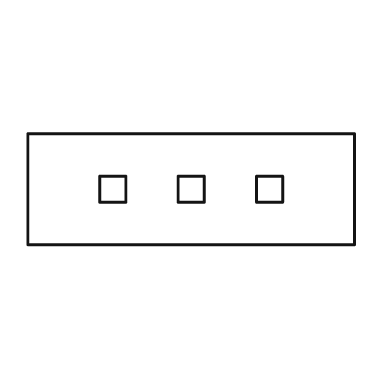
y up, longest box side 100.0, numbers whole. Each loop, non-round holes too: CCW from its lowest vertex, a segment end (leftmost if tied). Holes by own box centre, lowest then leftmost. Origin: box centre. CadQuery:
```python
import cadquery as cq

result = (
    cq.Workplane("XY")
    .moveTo(-50.0, -17.0)
    .lineTo(50.0, -17.0)
    .lineTo(50.0, 17.0)
    .lineTo(-50.0, 17.0)
    .close()
    .moveTo(-28.0, -4.0)
    .lineTo(-20.0, -4.0)
    .lineTo(-20.0, 4.0)
    .lineTo(-28.0, 4.0)
    .close()
    .moveTo(-4.0, -4.0)
    .lineTo(4.0, -4.0)
    .lineTo(4.0, 4.0)
    .lineTo(-4.0, 4.0)
    .close()
    .moveTo(20.0, -4.0)
    .lineTo(28.0, -4.0)
    .lineTo(28.0, 4.0)
    .lineTo(20.0, 4.0)
    .close()
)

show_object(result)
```